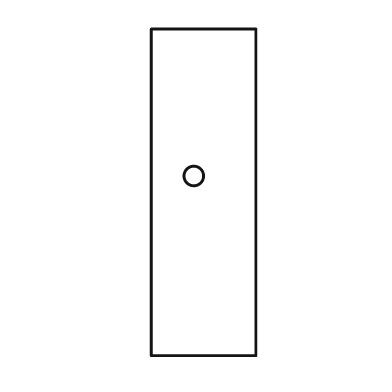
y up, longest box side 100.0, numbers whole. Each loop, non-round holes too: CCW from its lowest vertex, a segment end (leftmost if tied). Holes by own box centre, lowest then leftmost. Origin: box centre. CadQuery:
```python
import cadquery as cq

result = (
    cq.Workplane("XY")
    .moveTo(-16.0, -50.0)
    .lineTo(16.0, -50.0)
    .lineTo(16.0, 50.0)
    .lineTo(-16.0, 50.0)
    .close()
    .moveTo(-3.0, 5.0)
    .circle(3.0)
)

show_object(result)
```